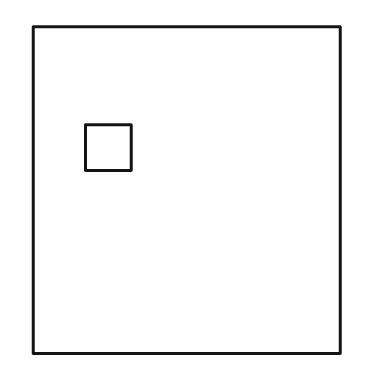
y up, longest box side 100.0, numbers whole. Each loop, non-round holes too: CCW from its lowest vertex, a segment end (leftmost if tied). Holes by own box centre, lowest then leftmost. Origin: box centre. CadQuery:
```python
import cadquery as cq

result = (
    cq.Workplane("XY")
    .moveTo(-47.0, -50.0)
    .lineTo(47.0, -50.0)
    .lineTo(47.0, 50.0)
    .lineTo(-47.0, 50.0)
    .close()
    .moveTo(-31.0, 6.0)
    .lineTo(-17.0, 6.0)
    .lineTo(-17.0, 20.0)
    .lineTo(-31.0, 20.0)
    .close()
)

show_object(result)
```